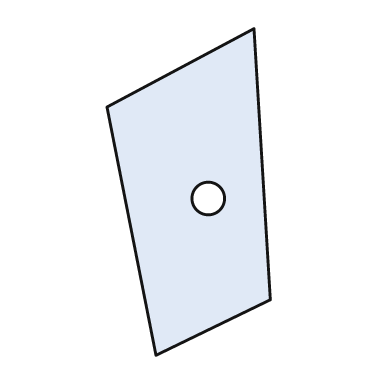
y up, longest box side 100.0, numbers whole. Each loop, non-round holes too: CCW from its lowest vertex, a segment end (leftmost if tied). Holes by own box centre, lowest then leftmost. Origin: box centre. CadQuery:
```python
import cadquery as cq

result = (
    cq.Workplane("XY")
    .moveTo(-10.0, -50.0)
    .lineTo(25.0, -33.0)
    .lineTo(20.0, 50.0)
    .lineTo(-25.0, 26.0)
    .close()
    .moveTo(6.0, -2.0)
    .circle(5.0)
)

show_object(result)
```